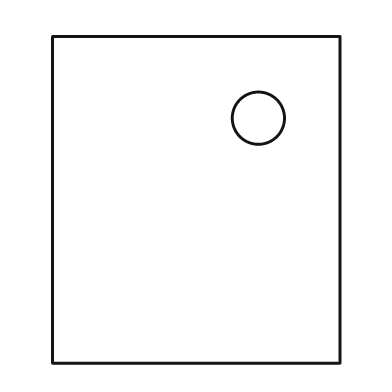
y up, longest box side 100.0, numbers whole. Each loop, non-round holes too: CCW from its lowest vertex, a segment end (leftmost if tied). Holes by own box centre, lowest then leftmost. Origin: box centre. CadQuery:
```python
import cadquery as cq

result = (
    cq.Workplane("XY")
    .moveTo(-44.0, -50.0)
    .lineTo(44.0, -50.0)
    .lineTo(44.0, 50.0)
    .lineTo(-44.0, 50.0)
    .close()
    .moveTo(19.0, 25.0)
    .circle(8.0)
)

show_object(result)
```